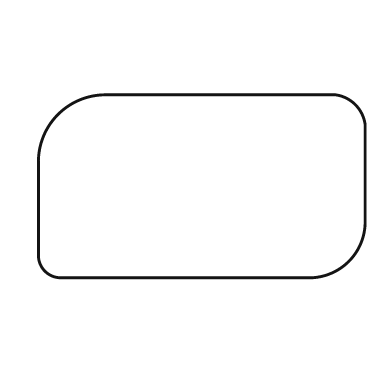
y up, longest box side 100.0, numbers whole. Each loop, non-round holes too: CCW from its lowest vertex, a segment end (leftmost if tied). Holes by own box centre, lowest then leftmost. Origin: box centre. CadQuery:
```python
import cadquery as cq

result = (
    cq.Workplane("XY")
    .moveTo(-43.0, -28.0)
    .lineTo(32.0, -28.0)
    .threePointArc((45.0, -23.0), (50.0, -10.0))
    .lineTo(50.0, 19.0)
    .threePointArc((47.0, 25.0), (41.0, 28.0))
    .lineTo(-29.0, 28.0)
    .threePointArc((-44.0, 22.0), (-50.0, 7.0))
    .lineTo(-50.0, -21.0)
    .threePointArc((-48.0, -26.0), (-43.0, -28.0))
    .close()
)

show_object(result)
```